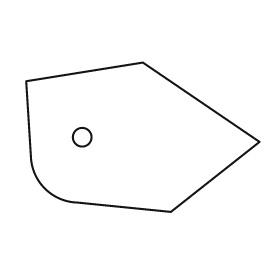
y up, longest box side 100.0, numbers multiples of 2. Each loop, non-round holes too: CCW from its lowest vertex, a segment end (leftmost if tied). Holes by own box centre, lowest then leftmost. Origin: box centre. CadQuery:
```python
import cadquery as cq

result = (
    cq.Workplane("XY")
    .moveTo(12.0, -32.0)
    .lineTo(50.0, -2.0)
    .lineTo(0.0, 32.0)
    .lineTo(-50.0, 24.0)
    .lineTo(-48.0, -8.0)
    .threePointArc((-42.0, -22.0), (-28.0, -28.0))
    .close()
    .moveTo(-26.0, 0.0)
    .circle(4.0)
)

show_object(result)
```